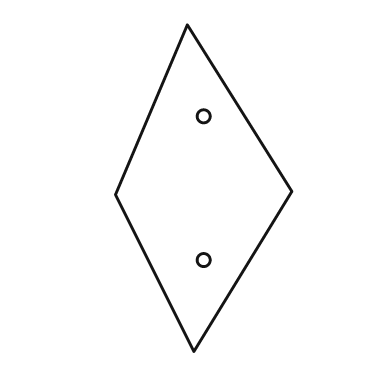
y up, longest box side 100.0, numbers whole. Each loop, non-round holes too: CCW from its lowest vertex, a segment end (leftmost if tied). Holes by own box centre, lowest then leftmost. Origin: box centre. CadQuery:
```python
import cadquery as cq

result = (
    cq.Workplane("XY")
    .moveTo(-3.0, -50.0)
    .lineTo(27.0, -1.0)
    .lineTo(-5.0, 50.0)
    .lineTo(-27.0, -2.0)
    .close()
    .moveTo(0.0, -22.0)
    .circle(2.0)
    .moveTo(0.0, 22.0)
    .circle(2.0)
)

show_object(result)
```